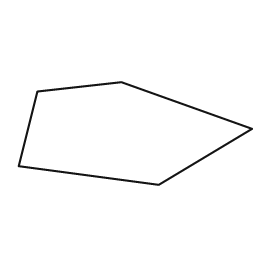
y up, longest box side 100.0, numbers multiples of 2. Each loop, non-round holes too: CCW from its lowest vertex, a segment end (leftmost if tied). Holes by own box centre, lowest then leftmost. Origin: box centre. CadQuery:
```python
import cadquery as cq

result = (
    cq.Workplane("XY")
    .moveTo(10.0, -22.0)
    .lineTo(50.0, 2.0)
    .lineTo(-6.0, 22.0)
    .lineTo(-42.0, 18.0)
    .lineTo(-50.0, -14.0)
    .close()
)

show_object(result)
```